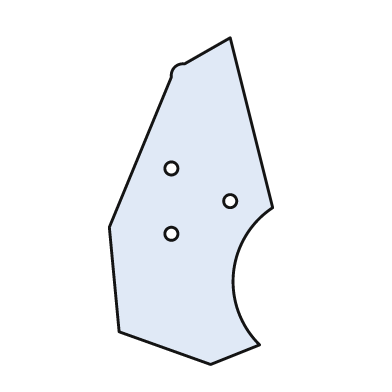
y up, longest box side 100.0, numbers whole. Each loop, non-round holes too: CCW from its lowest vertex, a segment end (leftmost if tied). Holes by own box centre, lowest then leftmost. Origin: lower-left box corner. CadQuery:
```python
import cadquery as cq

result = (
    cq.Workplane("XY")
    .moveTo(31.0, 0.0)
    .lineTo(46.0, 6.0)
    .threePointArc((38.0, 28.0), (50.0, 48.0))
    .lineTo(37.0, 100.0)
    .lineTo(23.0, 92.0)
    .threePointArc((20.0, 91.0), (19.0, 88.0))
    .lineTo(0.0, 42.0)
    .lineTo(3.0, 10.0)
    .close()
    .moveTo(19.0, 40.0)
    .circle(2.0)
    .moveTo(37.0, 50.0)
    .circle(2.0)
    .moveTo(19.0, 60.0)
    .circle(2.0)
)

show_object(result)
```